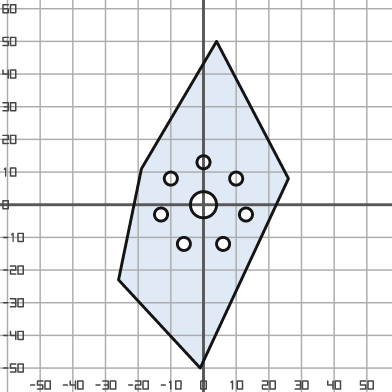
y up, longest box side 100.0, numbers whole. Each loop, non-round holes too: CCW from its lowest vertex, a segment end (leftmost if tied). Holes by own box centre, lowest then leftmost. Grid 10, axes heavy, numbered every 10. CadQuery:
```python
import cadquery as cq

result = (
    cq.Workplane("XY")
    .moveTo(-1.0, -50.0)
    .lineTo(26.0, 8.0)
    .lineTo(4.0, 50.0)
    .lineTo(-19.0, 11.0)
    .lineTo(-26.0, -23.0)
    .close()
    .moveTo(-6.0, -12.0)
    .circle(2.0)
    .moveTo(6.0, -12.0)
    .circle(2.0)
    .moveTo(-13.0, -3.0)
    .circle(2.0)
    .moveTo(13.0, -3.0)
    .circle(2.0)
    .moveTo(0.0, 0.0)
    .circle(4.0)
    .moveTo(-10.0, 8.0)
    .circle(2.0)
    .moveTo(10.0, 8.0)
    .circle(2.0)
    .moveTo(0.0, 13.0)
    .circle(2.0)
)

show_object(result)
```